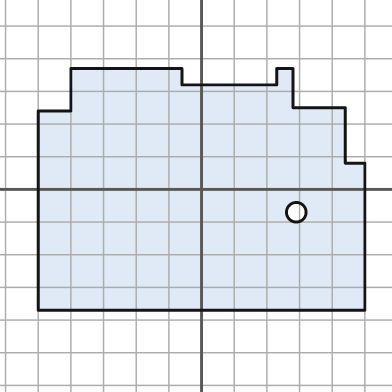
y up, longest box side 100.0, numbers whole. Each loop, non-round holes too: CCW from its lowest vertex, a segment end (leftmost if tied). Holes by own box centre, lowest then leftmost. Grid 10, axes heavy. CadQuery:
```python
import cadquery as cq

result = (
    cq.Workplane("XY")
    .moveTo(-50.0, -37.0)
    .lineTo(50.0, -37.0)
    .lineTo(50.0, 8.0)
    .lineTo(44.0, 8.0)
    .lineTo(44.0, 25.0)
    .lineTo(28.0, 25.0)
    .lineTo(28.0, 37.0)
    .lineTo(23.0, 37.0)
    .lineTo(23.0, 32.0)
    .lineTo(-6.0, 32.0)
    .lineTo(-6.0, 37.0)
    .lineTo(-40.0, 37.0)
    .lineTo(-40.0, 24.0)
    .lineTo(-50.0, 24.0)
    .close()
    .moveTo(29.0, -7.0)
    .circle(3.0)
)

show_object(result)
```